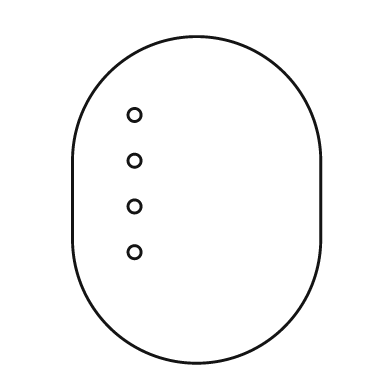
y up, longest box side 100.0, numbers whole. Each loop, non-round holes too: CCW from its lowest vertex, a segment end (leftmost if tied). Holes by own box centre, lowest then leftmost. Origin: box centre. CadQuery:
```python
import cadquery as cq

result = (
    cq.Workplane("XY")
    .moveTo(-38.0, -12.0)
    .threePointArc((0.0, -50.0), (38.0, -12.0))
    .lineTo(38.0, 12.0)
    .threePointArc((0.0, 50.0), (-38.0, 12.0))
    .close()
    .moveTo(-19.0, -16.0)
    .circle(2.0)
    .moveTo(-19.0, -2.0)
    .circle(2.0)
    .moveTo(-19.0, 12.0)
    .circle(2.0)
    .moveTo(-19.0, 26.0)
    .circle(2.0)
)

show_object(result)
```